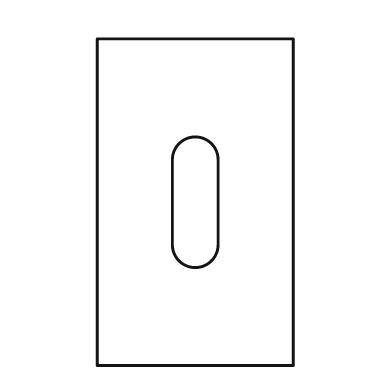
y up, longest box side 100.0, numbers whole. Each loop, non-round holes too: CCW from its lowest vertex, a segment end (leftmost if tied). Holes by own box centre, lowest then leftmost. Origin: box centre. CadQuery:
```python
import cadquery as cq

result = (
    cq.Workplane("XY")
    .moveTo(-30.0, -50.0)
    .lineTo(30.0, -50.0)
    .lineTo(30.0, 50.0)
    .lineTo(-30.0, 50.0)
    .close()
    .moveTo(-7.0, -13.0)
    .threePointArc((0.0, -20.0), (7.0, -13.0))
    .lineTo(7.0, 13.0)
    .threePointArc((0.0, 20.0), (-7.0, 13.0))
    .close()
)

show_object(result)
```